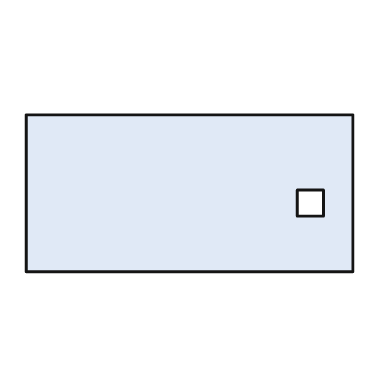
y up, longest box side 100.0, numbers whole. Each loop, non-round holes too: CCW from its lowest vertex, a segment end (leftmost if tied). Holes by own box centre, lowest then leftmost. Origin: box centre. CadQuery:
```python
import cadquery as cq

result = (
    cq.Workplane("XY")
    .moveTo(-50.0, -24.0)
    .lineTo(50.0, -24.0)
    .lineTo(50.0, 24.0)
    .lineTo(-50.0, 24.0)
    .close()
    .moveTo(33.0, -7.0)
    .lineTo(41.0, -7.0)
    .lineTo(41.0, 1.0)
    .lineTo(33.0, 1.0)
    .close()
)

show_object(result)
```